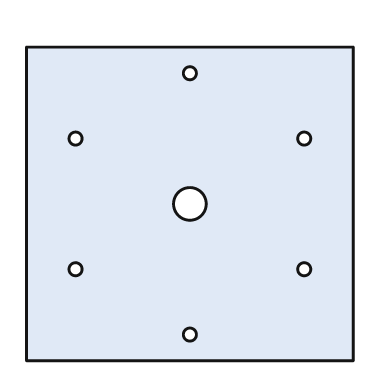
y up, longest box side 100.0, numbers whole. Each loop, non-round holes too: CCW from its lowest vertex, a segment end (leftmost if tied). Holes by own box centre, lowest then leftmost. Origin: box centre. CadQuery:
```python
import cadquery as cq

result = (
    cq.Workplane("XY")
    .moveTo(-50.0, -48.0)
    .lineTo(50.0, -48.0)
    .lineTo(50.0, 48.0)
    .lineTo(-50.0, 48.0)
    .close()
    .moveTo(0.0, -40.0)
    .circle(2.0)
    .moveTo(-35.0, -20.0)
    .circle(2.0)
    .moveTo(35.0, -20.0)
    .circle(2.0)
    .moveTo(0.0, 0.0)
    .circle(5.0)
    .moveTo(-35.0, 20.0)
    .circle(2.0)
    .moveTo(35.0, 20.0)
    .circle(2.0)
    .moveTo(0.0, 40.0)
    .circle(2.0)
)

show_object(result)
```